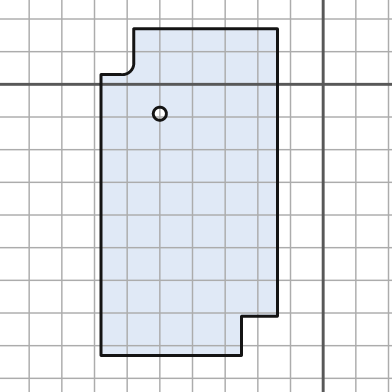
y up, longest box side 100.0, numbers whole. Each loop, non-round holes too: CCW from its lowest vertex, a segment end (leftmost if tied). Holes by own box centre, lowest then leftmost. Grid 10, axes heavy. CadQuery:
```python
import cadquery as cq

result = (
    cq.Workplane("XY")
    .moveTo(-68.0, -83.0)
    .lineTo(-25.0, -83.0)
    .lineTo(-25.0, -71.0)
    .lineTo(-14.0, -71.0)
    .lineTo(-14.0, 17.0)
    .lineTo(-58.0, 17.0)
    .lineTo(-58.0, 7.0)
    .threePointArc((-59.0, 4.0), (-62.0, 3.0))
    .lineTo(-68.0, 3.0)
    .close()
    .moveTo(-50.0, -9.0)
    .circle(2.0)
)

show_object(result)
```